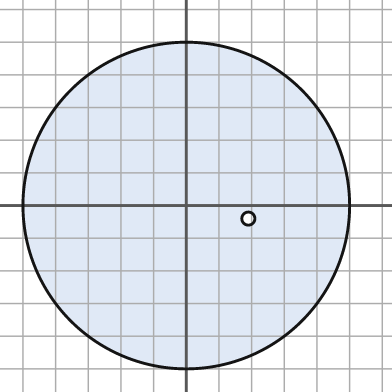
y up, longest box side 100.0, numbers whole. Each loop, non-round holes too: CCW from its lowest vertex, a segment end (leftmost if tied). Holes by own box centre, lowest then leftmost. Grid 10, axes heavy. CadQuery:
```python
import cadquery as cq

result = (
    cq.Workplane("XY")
    .moveTo(0.0, 0.0)
    .circle(50.0)
    .moveTo(19.0, -4.0)
    .circle(2.0)
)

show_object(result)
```